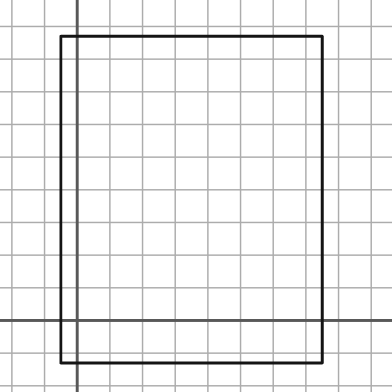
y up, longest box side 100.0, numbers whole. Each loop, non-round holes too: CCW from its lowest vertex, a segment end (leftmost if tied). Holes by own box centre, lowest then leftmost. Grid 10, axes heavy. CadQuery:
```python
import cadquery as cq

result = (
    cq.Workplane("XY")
    .moveTo(-5.0, -13.0)
    .lineTo(75.0, -13.0)
    .lineTo(75.0, 87.0)
    .lineTo(-5.0, 87.0)
    .close()
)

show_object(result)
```